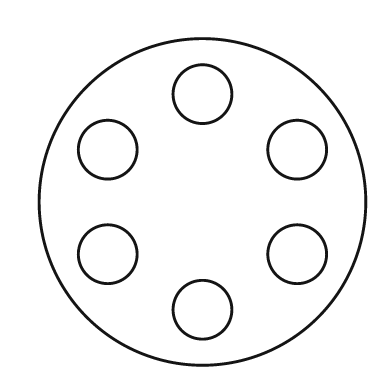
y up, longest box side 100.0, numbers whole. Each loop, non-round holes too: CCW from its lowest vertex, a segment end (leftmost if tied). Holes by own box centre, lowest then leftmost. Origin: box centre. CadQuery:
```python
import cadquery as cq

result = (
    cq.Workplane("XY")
    .moveTo(0.0, 0.0)
    .circle(50.0)
    .moveTo(0.0, -33.0)
    .circle(9.0)
    .moveTo(-29.0, -16.0)
    .circle(9.0)
    .moveTo(29.0, -16.0)
    .circle(9.0)
    .moveTo(-29.0, 16.0)
    .circle(9.0)
    .moveTo(29.0, 16.0)
    .circle(9.0)
    .moveTo(0.0, 33.0)
    .circle(9.0)
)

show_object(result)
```